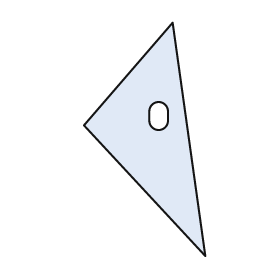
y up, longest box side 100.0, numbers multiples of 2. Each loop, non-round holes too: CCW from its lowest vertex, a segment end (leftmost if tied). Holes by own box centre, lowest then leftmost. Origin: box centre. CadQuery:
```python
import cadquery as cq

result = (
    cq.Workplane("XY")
    .moveTo(26.0, -50.0)
    .lineTo(12.0, 50.0)
    .lineTo(-26.0, 6.0)
    .close()
    .moveTo(2.0, 8.0)
    .threePointArc((6.0, 4.0), (10.0, 8.0))
    .lineTo(10.0, 12.0)
    .threePointArc((6.0, 16.0), (2.0, 12.0))
    .close()
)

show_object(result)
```